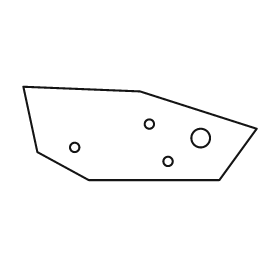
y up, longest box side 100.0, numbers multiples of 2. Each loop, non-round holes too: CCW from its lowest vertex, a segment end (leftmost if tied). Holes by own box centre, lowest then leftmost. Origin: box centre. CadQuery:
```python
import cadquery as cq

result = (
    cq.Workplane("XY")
    .moveTo(-22.0, -20.0)
    .lineTo(34.0, -20.0)
    .lineTo(50.0, 2.0)
    .lineTo(0.0, 18.0)
    .lineTo(-50.0, 20.0)
    .lineTo(-44.0, -8.0)
    .close()
    .moveTo(12.0, -12.0)
    .circle(2.0)
    .moveTo(-28.0, -6.0)
    .circle(2.0)
    .moveTo(26.0, -2.0)
    .circle(4.0)
    .moveTo(4.0, 4.0)
    .circle(2.0)
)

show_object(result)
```